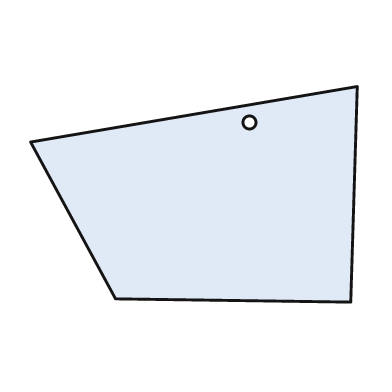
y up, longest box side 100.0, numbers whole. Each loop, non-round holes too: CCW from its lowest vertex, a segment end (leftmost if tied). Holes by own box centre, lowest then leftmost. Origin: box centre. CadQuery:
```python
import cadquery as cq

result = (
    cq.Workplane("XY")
    .moveTo(48.0, -33.0)
    .lineTo(50.0, 33.0)
    .lineTo(-50.0, 16.0)
    .lineTo(-24.0, -32.0)
    .close()
    .moveTo(17.0, 22.0)
    .circle(2.0)
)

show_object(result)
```